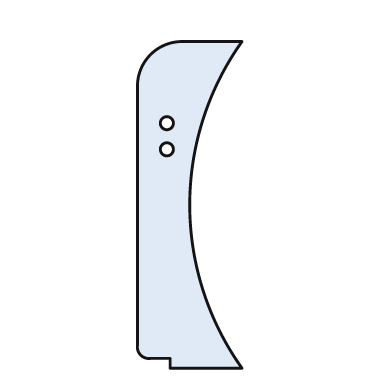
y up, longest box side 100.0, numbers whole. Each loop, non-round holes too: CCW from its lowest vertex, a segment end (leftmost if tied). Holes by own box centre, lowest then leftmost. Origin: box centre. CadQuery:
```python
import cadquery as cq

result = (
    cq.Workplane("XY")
    .moveTo(-6.0, -50.0)
    .lineTo(16.0, -50.0)
    .threePointArc((0.0, 0.0), (16.0, 50.0))
    .lineTo(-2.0, 50.0)
    .threePointArc((-12.0, 46.0), (-16.0, 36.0))
    .lineTo(-16.0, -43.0)
    .threePointArc((-15.0, -46.0), (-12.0, -47.0))
    .lineTo(-6.0, -47.0)
    .close()
    .moveTo(-7.0, 17.0)
    .circle(2.0)
    .moveTo(-7.0, 25.0)
    .circle(2.0)
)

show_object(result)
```